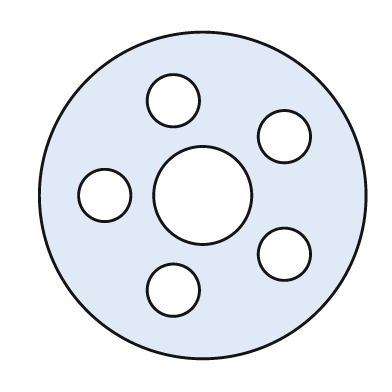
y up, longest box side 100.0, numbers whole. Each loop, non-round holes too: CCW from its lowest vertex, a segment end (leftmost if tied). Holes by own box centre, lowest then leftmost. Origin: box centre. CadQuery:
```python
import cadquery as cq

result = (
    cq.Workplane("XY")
    .moveTo(0.0, 0.0)
    .circle(50.0)
    .moveTo(-9.0, -29.0)
    .circle(8.0)
    .moveTo(25.0, -18.0)
    .circle(8.0)
    .moveTo(-30.0, 0.0)
    .circle(8.0)
    .moveTo(0.0, 0.0)
    .circle(15.0)
    .moveTo(25.0, 18.0)
    .circle(8.0)
    .moveTo(-9.0, 29.0)
    .circle(8.0)
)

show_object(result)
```